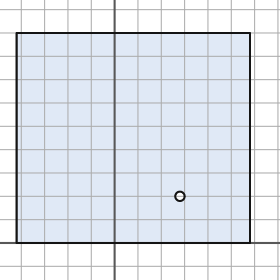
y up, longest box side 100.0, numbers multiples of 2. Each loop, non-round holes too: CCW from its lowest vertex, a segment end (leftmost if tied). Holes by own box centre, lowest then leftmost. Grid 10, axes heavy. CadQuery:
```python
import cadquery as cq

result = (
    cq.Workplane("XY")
    .moveTo(-42.0, 0.0)
    .lineTo(58.0, 0.0)
    .lineTo(58.0, 90.0)
    .lineTo(-42.0, 90.0)
    .close()
    .moveTo(28.0, 20.0)
    .circle(2.0)
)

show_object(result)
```